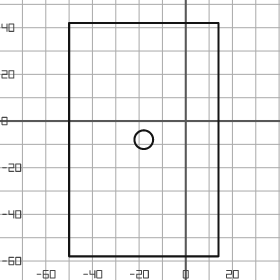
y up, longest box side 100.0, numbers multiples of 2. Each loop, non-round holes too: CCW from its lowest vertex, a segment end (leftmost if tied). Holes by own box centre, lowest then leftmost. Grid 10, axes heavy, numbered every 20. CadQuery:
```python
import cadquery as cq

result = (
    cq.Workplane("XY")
    .moveTo(-50.0, -58.0)
    .lineTo(14.0, -58.0)
    .lineTo(14.0, 42.0)
    .lineTo(-50.0, 42.0)
    .close()
    .moveTo(-18.0, -8.0)
    .circle(4.0)
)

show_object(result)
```